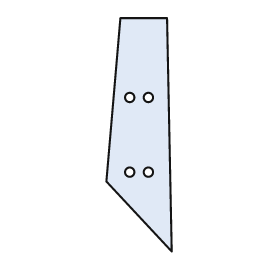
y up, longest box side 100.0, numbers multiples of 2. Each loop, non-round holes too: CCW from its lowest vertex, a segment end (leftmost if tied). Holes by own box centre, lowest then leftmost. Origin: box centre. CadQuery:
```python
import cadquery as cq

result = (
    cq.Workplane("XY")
    .moveTo(14.0, -50.0)
    .lineTo(12.0, 50.0)
    .lineTo(-8.0, 50.0)
    .lineTo(-14.0, -20.0)
    .close()
    .moveTo(-4.0, -16.0)
    .circle(2.0)
    .moveTo(4.0, -16.0)
    .circle(2.0)
    .moveTo(-4.0, 16.0)
    .circle(2.0)
    .moveTo(4.0, 16.0)
    .circle(2.0)
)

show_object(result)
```